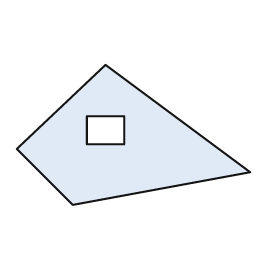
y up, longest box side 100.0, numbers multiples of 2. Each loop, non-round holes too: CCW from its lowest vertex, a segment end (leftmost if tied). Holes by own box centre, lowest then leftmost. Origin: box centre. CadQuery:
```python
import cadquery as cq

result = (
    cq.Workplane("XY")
    .moveTo(-26.0, -30.0)
    .lineTo(50.0, -16.0)
    .lineTo(-12.0, 30.0)
    .lineTo(-50.0, -6.0)
    .close()
    .moveTo(-20.0, -4.0)
    .lineTo(-4.0, -4.0)
    .lineTo(-4.0, 8.0)
    .lineTo(-20.0, 8.0)
    .close()
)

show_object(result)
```